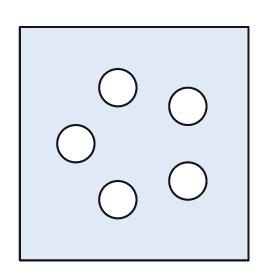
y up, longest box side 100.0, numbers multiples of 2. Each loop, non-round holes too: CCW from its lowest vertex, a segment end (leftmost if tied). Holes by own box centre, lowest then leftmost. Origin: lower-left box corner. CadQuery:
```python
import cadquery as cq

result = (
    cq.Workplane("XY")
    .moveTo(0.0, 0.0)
    .lineTo(98.0, 0.0)
    .lineTo(98.0, 100.0)
    .lineTo(0.0, 100.0)
    .close()
    .moveTo(42.0, 26.0)
    .circle(8.0)
    .moveTo(72.0, 34.0)
    .circle(8.0)
    .moveTo(24.0, 50.0)
    .circle(8.0)
    .moveTo(72.0, 66.0)
    .circle(8.0)
    .moveTo(42.0, 74.0)
    .circle(8.0)
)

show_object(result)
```